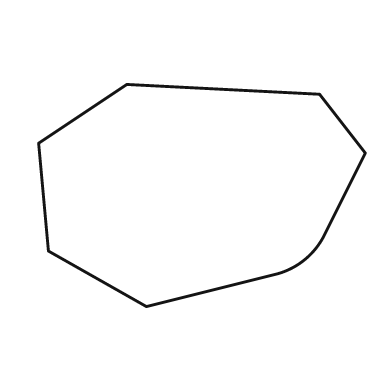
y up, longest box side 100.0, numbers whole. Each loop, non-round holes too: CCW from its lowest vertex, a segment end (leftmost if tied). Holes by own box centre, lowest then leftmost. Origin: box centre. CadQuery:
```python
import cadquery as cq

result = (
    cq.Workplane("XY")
    .moveTo(-17.0, -34.0)
    .lineTo(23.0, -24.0)
    .threePointArc((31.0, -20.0), (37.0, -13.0))
    .lineTo(50.0, 13.0)
    .lineTo(36.0, 31.0)
    .lineTo(-23.0, 34.0)
    .lineTo(-50.0, 16.0)
    .lineTo(-47.0, -17.0)
    .close()
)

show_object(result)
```